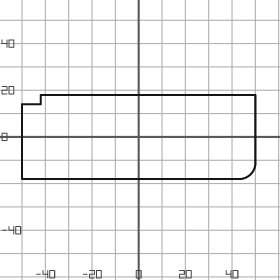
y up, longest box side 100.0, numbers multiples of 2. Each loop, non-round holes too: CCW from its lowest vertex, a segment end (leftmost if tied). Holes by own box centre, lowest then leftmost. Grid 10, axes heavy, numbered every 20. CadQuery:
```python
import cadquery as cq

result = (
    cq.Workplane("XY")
    .moveTo(-50.0, -18.0)
    .lineTo(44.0, -18.0)
    .threePointArc((48.0, -16.0), (50.0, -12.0))
    .lineTo(50.0, 18.0)
    .lineTo(-42.0, 18.0)
    .lineTo(-42.0, 14.0)
    .lineTo(-50.0, 14.0)
    .close()
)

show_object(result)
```